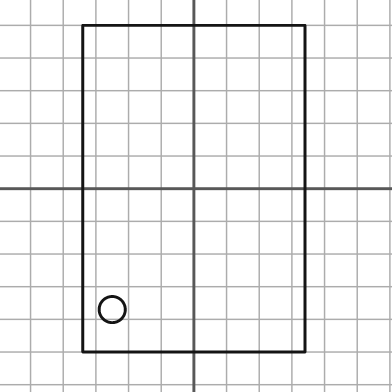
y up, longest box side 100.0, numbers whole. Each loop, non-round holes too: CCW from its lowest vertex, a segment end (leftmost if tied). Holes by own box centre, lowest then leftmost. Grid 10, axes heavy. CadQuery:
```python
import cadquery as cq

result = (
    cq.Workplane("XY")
    .moveTo(-34.0, -50.0)
    .lineTo(34.0, -50.0)
    .lineTo(34.0, 50.0)
    .lineTo(-34.0, 50.0)
    .close()
    .moveTo(-25.0, -37.0)
    .circle(4.0)
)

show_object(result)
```